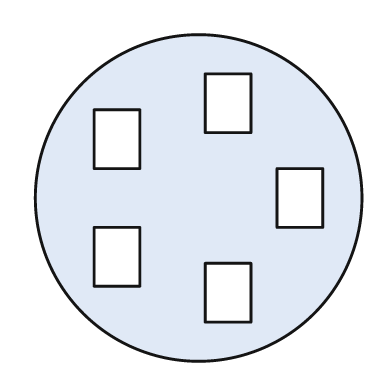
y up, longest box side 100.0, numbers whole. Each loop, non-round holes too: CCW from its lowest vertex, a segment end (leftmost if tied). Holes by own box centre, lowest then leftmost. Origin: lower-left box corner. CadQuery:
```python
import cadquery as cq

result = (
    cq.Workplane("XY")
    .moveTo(50.0, 50.0)
    .circle(50.0)
    .moveTo(52.0, 12.0)
    .lineTo(66.0, 12.0)
    .lineTo(66.0, 30.0)
    .lineTo(52.0, 30.0)
    .close()
    .moveTo(18.0, 23.0)
    .lineTo(32.0, 23.0)
    .lineTo(32.0, 41.0)
    .lineTo(18.0, 41.0)
    .close()
    .moveTo(74.0, 41.0)
    .lineTo(88.0, 41.0)
    .lineTo(88.0, 59.0)
    .lineTo(74.0, 59.0)
    .close()
    .moveTo(18.0, 59.0)
    .lineTo(32.0, 59.0)
    .lineTo(32.0, 77.0)
    .lineTo(18.0, 77.0)
    .close()
    .moveTo(52.0, 70.0)
    .lineTo(66.0, 70.0)
    .lineTo(66.0, 88.0)
    .lineTo(52.0, 88.0)
    .close()
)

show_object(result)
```